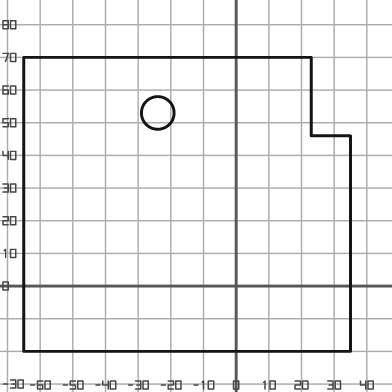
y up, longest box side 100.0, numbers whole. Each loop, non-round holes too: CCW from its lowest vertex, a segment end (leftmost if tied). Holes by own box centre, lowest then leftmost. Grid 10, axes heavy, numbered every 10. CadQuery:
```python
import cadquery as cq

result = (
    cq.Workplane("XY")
    .moveTo(-65.0, -20.0)
    .lineTo(35.0, -20.0)
    .lineTo(35.0, 46.0)
    .lineTo(23.0, 46.0)
    .lineTo(23.0, 70.0)
    .lineTo(-65.0, 70.0)
    .close()
    .moveTo(-24.0, 53.0)
    .circle(5.0)
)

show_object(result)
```